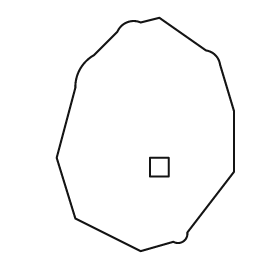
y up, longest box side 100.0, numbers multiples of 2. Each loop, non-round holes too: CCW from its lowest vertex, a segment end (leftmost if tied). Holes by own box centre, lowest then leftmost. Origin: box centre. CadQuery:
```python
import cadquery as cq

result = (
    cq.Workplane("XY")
    .moveTo(-2.0, -50.0)
    .lineTo(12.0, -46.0)
    .threePointArc((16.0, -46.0), (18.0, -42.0))
    .lineTo(38.0, -16.0)
    .lineTo(38.0, 10.0)
    .lineTo(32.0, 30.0)
    .threePointArc((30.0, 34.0), (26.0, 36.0))
    .lineTo(6.0, 50.0)
    .lineTo(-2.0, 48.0)
    .threePointArc((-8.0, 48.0), (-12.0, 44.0))
    .lineTo(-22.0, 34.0)
    .threePointArc((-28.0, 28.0), (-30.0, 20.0))
    .lineTo(-38.0, -10.0)
    .lineTo(-30.0, -36.0)
    .close()
    .moveTo(2.0, -18.0)
    .lineTo(10.0, -18.0)
    .lineTo(10.0, -10.0)
    .lineTo(2.0, -10.0)
    .close()
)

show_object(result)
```